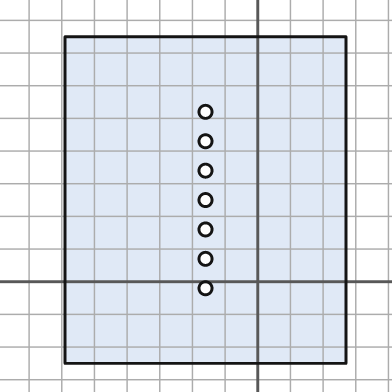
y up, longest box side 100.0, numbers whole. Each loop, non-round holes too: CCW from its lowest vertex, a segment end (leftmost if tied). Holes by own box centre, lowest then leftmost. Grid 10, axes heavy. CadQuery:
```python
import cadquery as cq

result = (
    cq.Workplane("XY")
    .moveTo(-59.0, -25.0)
    .lineTo(27.0, -25.0)
    .lineTo(27.0, 75.0)
    .lineTo(-59.0, 75.0)
    .close()
    .moveTo(-16.0, -2.0)
    .circle(2.0)
    .moveTo(-16.0, 7.0)
    .circle(2.0)
    .moveTo(-16.0, 16.0)
    .circle(2.0)
    .moveTo(-16.0, 25.0)
    .circle(2.0)
    .moveTo(-16.0, 34.0)
    .circle(2.0)
    .moveTo(-16.0, 43.0)
    .circle(2.0)
    .moveTo(-16.0, 52.0)
    .circle(2.0)
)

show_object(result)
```